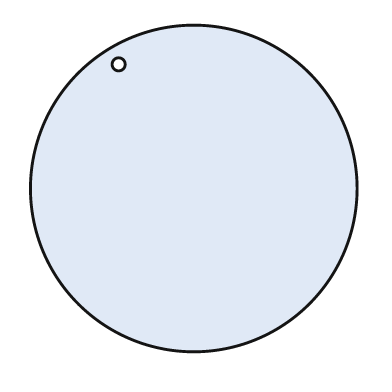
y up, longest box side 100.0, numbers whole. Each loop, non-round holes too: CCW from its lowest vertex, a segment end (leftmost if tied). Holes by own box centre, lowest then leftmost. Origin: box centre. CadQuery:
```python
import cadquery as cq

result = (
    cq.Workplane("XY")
    .moveTo(0.0, 0.0)
    .circle(50.0)
    .moveTo(-23.0, 38.0)
    .circle(2.0)
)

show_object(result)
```